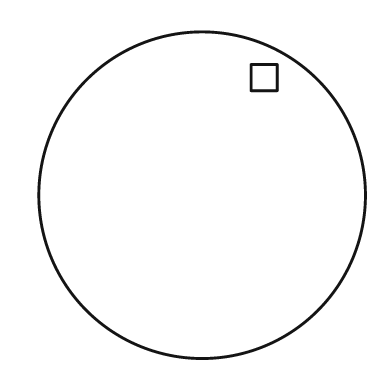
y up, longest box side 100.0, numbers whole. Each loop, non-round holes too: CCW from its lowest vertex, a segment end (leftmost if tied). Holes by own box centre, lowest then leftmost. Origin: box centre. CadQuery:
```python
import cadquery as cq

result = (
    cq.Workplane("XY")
    .moveTo(0.0, 0.0)
    .circle(50.0)
    .moveTo(15.0, 32.0)
    .lineTo(23.0, 32.0)
    .lineTo(23.0, 40.0)
    .lineTo(15.0, 40.0)
    .close()
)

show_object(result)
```